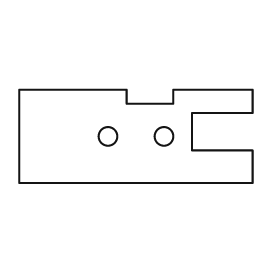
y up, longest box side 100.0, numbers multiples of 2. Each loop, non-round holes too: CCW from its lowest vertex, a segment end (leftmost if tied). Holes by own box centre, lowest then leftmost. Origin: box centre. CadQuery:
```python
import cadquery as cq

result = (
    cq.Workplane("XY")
    .moveTo(-50.0, -20.0)
    .lineTo(50.0, -20.0)
    .lineTo(50.0, -6.0)
    .lineTo(24.0, -6.0)
    .lineTo(24.0, 10.0)
    .lineTo(50.0, 10.0)
    .lineTo(50.0, 20.0)
    .lineTo(16.0, 20.0)
    .lineTo(16.0, 14.0)
    .lineTo(-4.0, 14.0)
    .lineTo(-4.0, 20.0)
    .lineTo(-50.0, 20.0)
    .close()
    .moveTo(-12.0, 0.0)
    .circle(4.0)
    .moveTo(12.0, 0.0)
    .circle(4.0)
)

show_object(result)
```